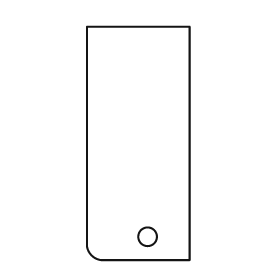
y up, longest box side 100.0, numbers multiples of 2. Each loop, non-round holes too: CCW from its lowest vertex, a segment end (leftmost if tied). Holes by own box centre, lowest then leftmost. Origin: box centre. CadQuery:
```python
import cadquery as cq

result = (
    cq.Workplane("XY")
    .moveTo(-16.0, -50.0)
    .lineTo(22.0, -50.0)
    .lineTo(22.0, 50.0)
    .lineTo(-22.0, 50.0)
    .lineTo(-22.0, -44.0)
    .threePointArc((-20.0, -48.0), (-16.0, -50.0))
    .close()
    .moveTo(4.0, -40.0)
    .circle(4.0)
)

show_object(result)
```